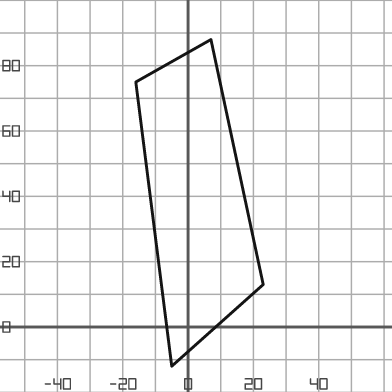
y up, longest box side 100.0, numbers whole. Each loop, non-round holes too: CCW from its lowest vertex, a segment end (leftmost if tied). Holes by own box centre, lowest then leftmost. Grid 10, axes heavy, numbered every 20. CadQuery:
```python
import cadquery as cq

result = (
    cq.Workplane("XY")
    .moveTo(-5.0, -12.0)
    .lineTo(23.0, 13.0)
    .lineTo(7.0, 88.0)
    .lineTo(-16.0, 75.0)
    .close()
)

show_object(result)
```